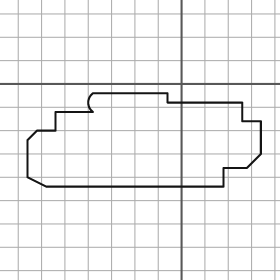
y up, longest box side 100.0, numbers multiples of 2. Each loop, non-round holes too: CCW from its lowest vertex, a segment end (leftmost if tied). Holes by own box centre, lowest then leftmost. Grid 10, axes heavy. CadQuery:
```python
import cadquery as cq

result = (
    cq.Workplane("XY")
    .moveTo(-58.0, -44.0)
    .lineTo(18.0, -44.0)
    .lineTo(18.0, -36.0)
    .lineTo(28.0, -36.0)
    .lineTo(34.0, -30.0)
    .lineTo(34.0, -16.0)
    .lineTo(26.0, -16.0)
    .lineTo(26.0, -8.0)
    .lineTo(-6.0, -8.0)
    .lineTo(-6.0, -4.0)
    .lineTo(-38.0, -4.0)
    .threePointArc((-40.0, -8.0), (-38.0, -12.0))
    .lineTo(-54.0, -12.0)
    .lineTo(-54.0, -20.0)
    .lineTo(-62.0, -20.0)
    .lineTo(-66.0, -24.0)
    .lineTo(-66.0, -40.0)
    .close()
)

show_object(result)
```